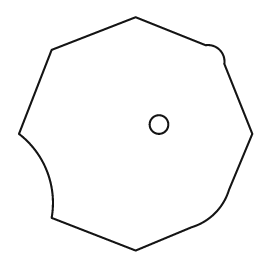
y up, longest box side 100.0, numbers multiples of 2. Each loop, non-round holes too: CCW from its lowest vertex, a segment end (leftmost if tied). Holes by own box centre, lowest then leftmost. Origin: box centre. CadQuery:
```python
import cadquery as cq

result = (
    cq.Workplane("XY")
    .moveTo(0.0, -50.0)
    .lineTo(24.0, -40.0)
    .threePointArc((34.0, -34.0), (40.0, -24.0))
    .lineTo(50.0, 0.0)
    .lineTo(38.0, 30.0)
    .threePointArc((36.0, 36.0), (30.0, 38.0))
    .lineTo(0.0, 50.0)
    .lineTo(-36.0, 36.0)
    .lineTo(-50.0, 0.0)
    .threePointArc((-38.0, -16.0), (-36.0, -36.0))
    .close()
    .moveTo(10.0, 4.0)
    .circle(4.0)
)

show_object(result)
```